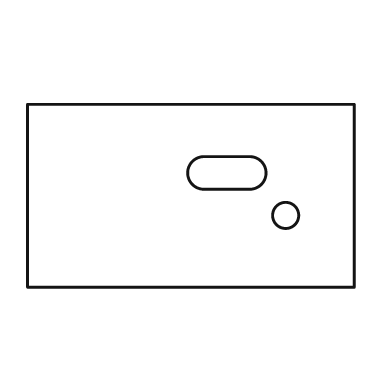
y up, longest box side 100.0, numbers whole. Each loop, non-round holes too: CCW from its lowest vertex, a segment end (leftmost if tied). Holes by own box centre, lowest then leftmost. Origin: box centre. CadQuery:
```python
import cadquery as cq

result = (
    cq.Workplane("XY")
    .moveTo(-50.0, -28.0)
    .lineTo(50.0, -28.0)
    .lineTo(50.0, 28.0)
    .lineTo(-50.0, 28.0)
    .close()
    .moveTo(29.0, -6.0)
    .circle(4.0)
    .moveTo(4.0, 2.0)
    .lineTo(18.0, 2.0)
    .threePointArc((23.0, 7.0), (18.0, 12.0))
    .lineTo(4.0, 12.0)
    .threePointArc((-1.0, 7.0), (4.0, 2.0))
    .close()
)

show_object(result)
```